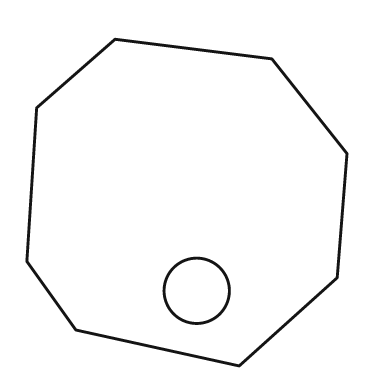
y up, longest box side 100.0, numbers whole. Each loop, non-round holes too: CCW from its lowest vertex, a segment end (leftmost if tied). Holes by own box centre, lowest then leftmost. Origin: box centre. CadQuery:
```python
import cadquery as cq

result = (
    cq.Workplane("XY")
    .moveTo(16.0, -50.0)
    .lineTo(46.0, -23.0)
    .lineTo(49.0, 15.0)
    .lineTo(26.0, 44.0)
    .lineTo(-22.0, 50.0)
    .lineTo(-46.0, 29.0)
    .lineTo(-49.0, -18.0)
    .lineTo(-34.0, -39.0)
    .close()
    .moveTo(3.0, -27.0)
    .circle(10.0)
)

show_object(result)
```